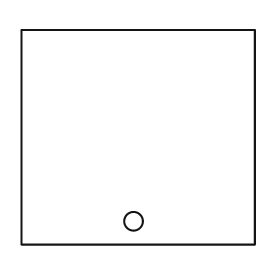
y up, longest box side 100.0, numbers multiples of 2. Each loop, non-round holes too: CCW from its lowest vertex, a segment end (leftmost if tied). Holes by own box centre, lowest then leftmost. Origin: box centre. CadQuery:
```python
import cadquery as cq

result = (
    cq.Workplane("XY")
    .moveTo(-50.0, -46.0)
    .lineTo(50.0, -46.0)
    .lineTo(50.0, 46.0)
    .lineTo(-50.0, 46.0)
    .close()
    .moveTo(-2.0, -36.0)
    .circle(4.0)
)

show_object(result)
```